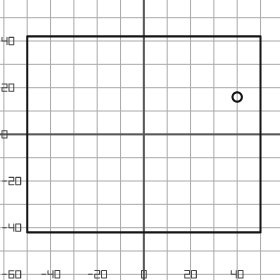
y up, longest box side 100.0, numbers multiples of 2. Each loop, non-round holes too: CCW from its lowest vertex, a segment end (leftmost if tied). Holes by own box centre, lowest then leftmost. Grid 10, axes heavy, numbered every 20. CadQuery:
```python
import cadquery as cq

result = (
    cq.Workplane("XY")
    .moveTo(-50.0, -42.0)
    .lineTo(50.0, -42.0)
    .lineTo(50.0, 42.0)
    .lineTo(-50.0, 42.0)
    .close()
    .moveTo(40.0, 16.0)
    .circle(2.0)
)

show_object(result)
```